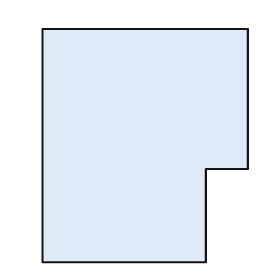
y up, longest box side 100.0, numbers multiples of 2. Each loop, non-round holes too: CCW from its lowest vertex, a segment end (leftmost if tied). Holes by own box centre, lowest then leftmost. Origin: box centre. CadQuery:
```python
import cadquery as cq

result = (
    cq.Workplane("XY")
    .moveTo(-44.0, -50.0)
    .lineTo(26.0, -50.0)
    .lineTo(26.0, -10.0)
    .lineTo(44.0, -10.0)
    .lineTo(44.0, 50.0)
    .lineTo(-44.0, 50.0)
    .close()
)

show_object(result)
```